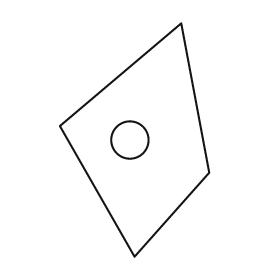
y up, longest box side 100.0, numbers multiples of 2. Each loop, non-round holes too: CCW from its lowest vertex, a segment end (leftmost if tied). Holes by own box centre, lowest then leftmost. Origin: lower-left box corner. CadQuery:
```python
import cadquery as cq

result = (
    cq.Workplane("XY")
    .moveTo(32.0, 0.0)
    .lineTo(64.0, 36.0)
    .lineTo(52.0, 100.0)
    .lineTo(0.0, 56.0)
    .close()
    .moveTo(30.0, 50.0)
    .circle(8.0)
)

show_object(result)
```